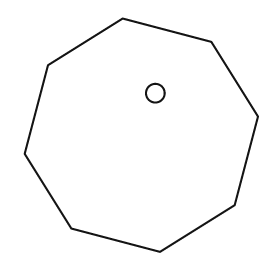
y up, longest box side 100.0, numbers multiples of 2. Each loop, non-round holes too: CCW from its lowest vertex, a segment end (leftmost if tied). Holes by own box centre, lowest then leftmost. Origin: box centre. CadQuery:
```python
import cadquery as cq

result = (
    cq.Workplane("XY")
    .moveTo(8.0, -50.0)
    .lineTo(40.0, -30.0)
    .lineTo(50.0, 8.0)
    .lineTo(30.0, 40.0)
    .lineTo(-8.0, 50.0)
    .lineTo(-40.0, 30.0)
    .lineTo(-50.0, -8.0)
    .lineTo(-30.0, -40.0)
    .close()
    .moveTo(6.0, 18.0)
    .circle(4.0)
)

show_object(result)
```